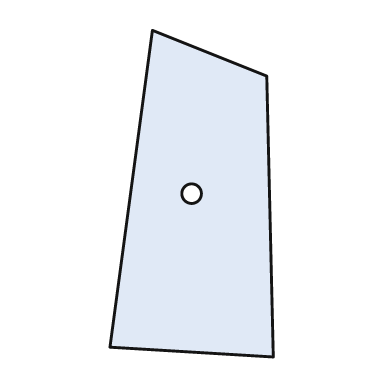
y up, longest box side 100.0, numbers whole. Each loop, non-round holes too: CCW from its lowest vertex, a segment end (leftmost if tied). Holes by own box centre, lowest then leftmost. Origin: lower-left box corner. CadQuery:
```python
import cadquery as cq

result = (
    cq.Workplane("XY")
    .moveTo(50.0, 0.0)
    .lineTo(48.0, 86.0)
    .lineTo(13.0, 100.0)
    .lineTo(0.0, 3.0)
    .close()
    .moveTo(25.0, 50.0)
    .circle(3.0)
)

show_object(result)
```